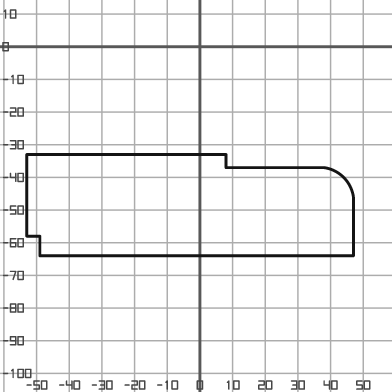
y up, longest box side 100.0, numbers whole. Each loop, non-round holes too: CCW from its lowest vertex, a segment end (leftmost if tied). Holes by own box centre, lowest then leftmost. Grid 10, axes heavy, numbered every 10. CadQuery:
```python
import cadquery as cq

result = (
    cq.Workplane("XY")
    .moveTo(-49.0, -64.0)
    .lineTo(47.0, -64.0)
    .lineTo(47.0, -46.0)
    .threePointArc((44.0, -40.0), (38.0, -37.0))
    .lineTo(8.0, -37.0)
    .lineTo(8.0, -33.0)
    .lineTo(-53.0, -33.0)
    .lineTo(-53.0, -58.0)
    .lineTo(-49.0, -58.0)
    .close()
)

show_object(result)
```